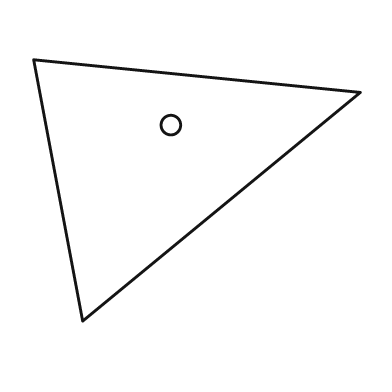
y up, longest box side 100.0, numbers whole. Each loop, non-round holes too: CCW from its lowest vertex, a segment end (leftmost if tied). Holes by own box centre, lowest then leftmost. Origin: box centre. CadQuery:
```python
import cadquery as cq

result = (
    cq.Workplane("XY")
    .moveTo(-35.0, -40.0)
    .lineTo(50.0, 30.0)
    .lineTo(-50.0, 40.0)
    .close()
    .moveTo(-8.0, 20.0)
    .circle(3.0)
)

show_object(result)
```